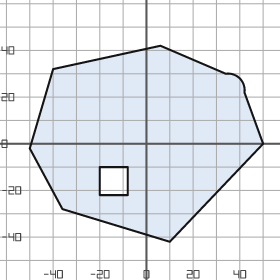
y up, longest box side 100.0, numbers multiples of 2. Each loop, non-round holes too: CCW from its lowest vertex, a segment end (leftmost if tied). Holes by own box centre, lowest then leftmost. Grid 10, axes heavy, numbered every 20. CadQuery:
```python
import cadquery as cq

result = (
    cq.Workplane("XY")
    .moveTo(10.0, -42.0)
    .lineTo(50.0, 0.0)
    .lineTo(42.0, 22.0)
    .threePointArc((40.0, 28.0), (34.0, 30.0))
    .lineTo(6.0, 42.0)
    .lineTo(-40.0, 32.0)
    .lineTo(-50.0, -2.0)
    .lineTo(-36.0, -28.0)
    .close()
    .moveTo(-20.0, -22.0)
    .lineTo(-8.0, -22.0)
    .lineTo(-8.0, -10.0)
    .lineTo(-20.0, -10.0)
    .close()
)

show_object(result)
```